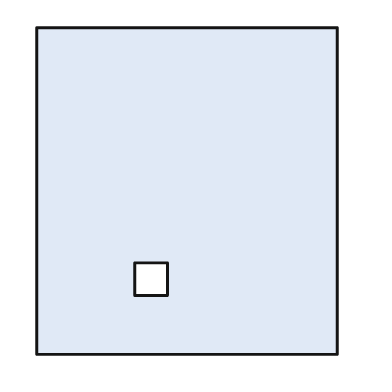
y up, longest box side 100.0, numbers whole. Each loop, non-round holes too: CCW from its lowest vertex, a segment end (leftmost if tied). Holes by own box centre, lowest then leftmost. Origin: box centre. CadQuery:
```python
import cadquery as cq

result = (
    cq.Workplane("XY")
    .moveTo(-46.0, -50.0)
    .lineTo(46.0, -50.0)
    .lineTo(46.0, 50.0)
    .lineTo(-46.0, 50.0)
    .close()
    .moveTo(-16.0, -32.0)
    .lineTo(-6.0, -32.0)
    .lineTo(-6.0, -22.0)
    .lineTo(-16.0, -22.0)
    .close()
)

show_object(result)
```